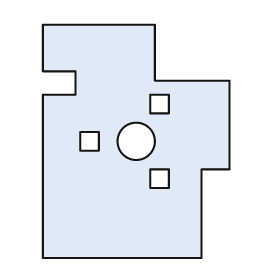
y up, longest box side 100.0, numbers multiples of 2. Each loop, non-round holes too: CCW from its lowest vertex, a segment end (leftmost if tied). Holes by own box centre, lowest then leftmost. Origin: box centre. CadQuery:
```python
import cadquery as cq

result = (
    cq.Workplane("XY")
    .moveTo(-40.0, -50.0)
    .lineTo(28.0, -50.0)
    .lineTo(28.0, -12.0)
    .lineTo(40.0, -12.0)
    .lineTo(40.0, 26.0)
    .lineTo(8.0, 26.0)
    .lineTo(8.0, 50.0)
    .lineTo(-40.0, 50.0)
    .lineTo(-40.0, 30.0)
    .lineTo(-26.0, 30.0)
    .lineTo(-26.0, 20.0)
    .lineTo(-40.0, 20.0)
    .close()
    .moveTo(6.0, -20.0)
    .lineTo(14.0, -20.0)
    .lineTo(14.0, -12.0)
    .lineTo(6.0, -12.0)
    .close()
    .moveTo(-24.0, -4.0)
    .lineTo(-16.0, -4.0)
    .lineTo(-16.0, 4.0)
    .lineTo(-24.0, 4.0)
    .close()
    .moveTo(0.0, 0.0)
    .circle(8.0)
    .moveTo(6.0, 12.0)
    .lineTo(14.0, 12.0)
    .lineTo(14.0, 20.0)
    .lineTo(6.0, 20.0)
    .close()
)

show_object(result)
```